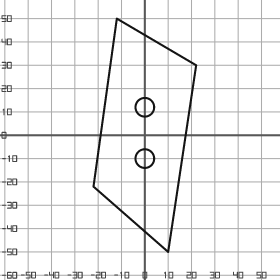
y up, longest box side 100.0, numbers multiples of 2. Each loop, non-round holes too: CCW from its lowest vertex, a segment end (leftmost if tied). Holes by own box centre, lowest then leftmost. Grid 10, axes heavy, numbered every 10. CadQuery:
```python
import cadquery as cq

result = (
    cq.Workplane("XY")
    .moveTo(10.0, -50.0)
    .lineTo(22.0, 30.0)
    .lineTo(-12.0, 50.0)
    .lineTo(-22.0, -22.0)
    .close()
    .moveTo(0.0, -10.0)
    .circle(4.0)
    .moveTo(0.0, 12.0)
    .circle(4.0)
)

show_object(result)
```